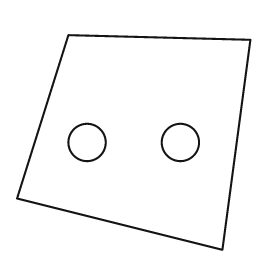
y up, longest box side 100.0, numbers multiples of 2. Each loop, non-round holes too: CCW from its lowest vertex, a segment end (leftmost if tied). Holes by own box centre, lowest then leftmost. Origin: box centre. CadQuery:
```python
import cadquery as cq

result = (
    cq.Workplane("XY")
    .moveTo(38.0, -46.0)
    .lineTo(50.0, 44.0)
    .lineTo(-28.0, 46.0)
    .lineTo(-50.0, -24.0)
    .close()
    .moveTo(-20.0, 0.0)
    .circle(8.0)
    .moveTo(20.0, 0.0)
    .circle(8.0)
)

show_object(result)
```